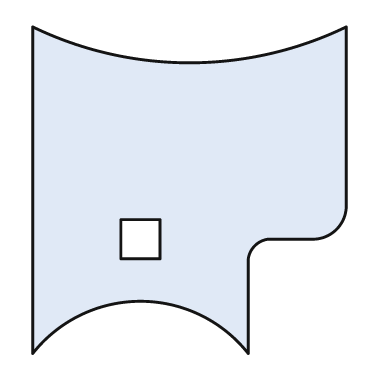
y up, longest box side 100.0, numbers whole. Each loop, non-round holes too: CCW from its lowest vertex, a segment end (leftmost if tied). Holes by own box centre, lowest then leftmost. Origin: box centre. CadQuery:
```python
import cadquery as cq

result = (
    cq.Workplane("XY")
    .moveTo(-48.0, -50.0)
    .threePointArc((-15.0, -34.0), (18.0, -50.0))
    .lineTo(18.0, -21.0)
    .threePointArc((20.0, -17.0), (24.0, -15.0))
    .lineTo(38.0, -15.0)
    .threePointArc((45.0, -12.0), (48.0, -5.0))
    .lineTo(48.0, 50.0)
    .threePointArc((0.0, 39.0), (-48.0, 50.0))
    .close()
    .moveTo(-21.0, -21.0)
    .lineTo(-9.0, -21.0)
    .lineTo(-9.0, -9.0)
    .lineTo(-21.0, -9.0)
    .close()
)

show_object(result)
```